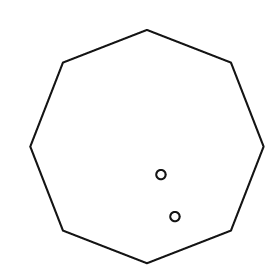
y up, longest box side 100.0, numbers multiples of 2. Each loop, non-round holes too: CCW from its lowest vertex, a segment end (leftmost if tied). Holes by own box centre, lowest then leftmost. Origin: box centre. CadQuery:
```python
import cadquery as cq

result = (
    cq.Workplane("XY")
    .moveTo(0.0, -50.0)
    .lineTo(36.0, -36.0)
    .lineTo(50.0, 0.0)
    .lineTo(36.0, 36.0)
    .lineTo(0.0, 50.0)
    .lineTo(-36.0, 36.0)
    .lineTo(-50.0, 0.0)
    .lineTo(-36.0, -36.0)
    .close()
    .moveTo(12.0, -30.0)
    .circle(2.0)
    .moveTo(6.0, -12.0)
    .circle(2.0)
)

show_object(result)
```